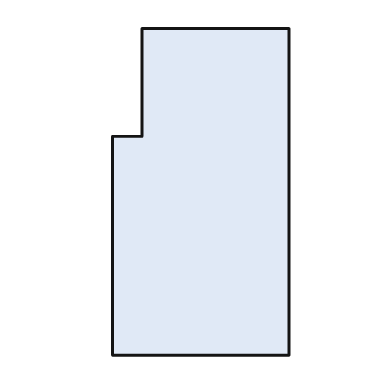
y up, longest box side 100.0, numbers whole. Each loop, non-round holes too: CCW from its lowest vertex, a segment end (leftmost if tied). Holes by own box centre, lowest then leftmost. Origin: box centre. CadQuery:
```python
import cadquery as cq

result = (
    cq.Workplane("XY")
    .moveTo(-27.0, -50.0)
    .lineTo(27.0, -50.0)
    .lineTo(27.0, 50.0)
    .lineTo(-18.0, 50.0)
    .lineTo(-18.0, 17.0)
    .lineTo(-27.0, 17.0)
    .close()
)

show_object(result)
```